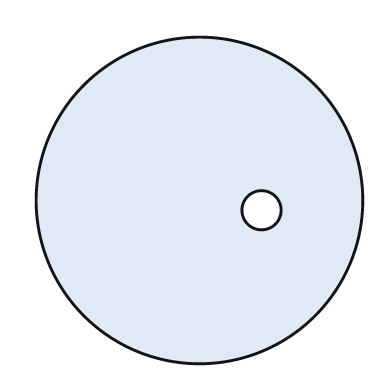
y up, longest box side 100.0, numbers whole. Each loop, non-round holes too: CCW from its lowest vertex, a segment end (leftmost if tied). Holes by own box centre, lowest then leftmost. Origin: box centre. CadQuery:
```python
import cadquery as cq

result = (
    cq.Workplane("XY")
    .moveTo(0.0, 0.0)
    .circle(50.0)
    .moveTo(19.0, -3.0)
    .circle(6.0)
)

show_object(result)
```